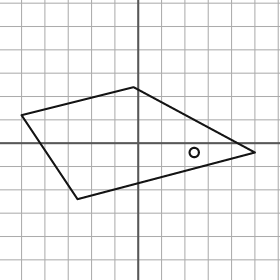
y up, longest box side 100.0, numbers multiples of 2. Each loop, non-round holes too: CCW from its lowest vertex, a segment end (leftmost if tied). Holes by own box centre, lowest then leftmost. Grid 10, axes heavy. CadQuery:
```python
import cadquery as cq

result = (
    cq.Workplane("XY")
    .moveTo(-26.0, -24.0)
    .lineTo(50.0, -4.0)
    .lineTo(-2.0, 24.0)
    .lineTo(-50.0, 12.0)
    .close()
    .moveTo(24.0, -4.0)
    .circle(2.0)
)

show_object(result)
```